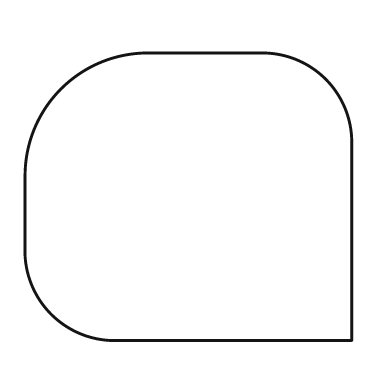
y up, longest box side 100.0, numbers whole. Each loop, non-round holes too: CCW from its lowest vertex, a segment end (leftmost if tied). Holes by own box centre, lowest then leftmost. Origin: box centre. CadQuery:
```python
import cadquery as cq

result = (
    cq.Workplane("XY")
    .moveTo(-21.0, -44.0)
    .lineTo(50.0, -44.0)
    .lineTo(50.0, 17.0)
    .threePointArc((42.0, 36.0), (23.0, 44.0))
    .lineTo(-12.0, 44.0)
    .threePointArc((-39.0, 33.0), (-50.0, 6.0))
    .lineTo(-50.0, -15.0)
    .threePointArc((-42.0, -36.0), (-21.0, -44.0))
    .close()
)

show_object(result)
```